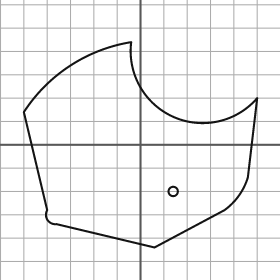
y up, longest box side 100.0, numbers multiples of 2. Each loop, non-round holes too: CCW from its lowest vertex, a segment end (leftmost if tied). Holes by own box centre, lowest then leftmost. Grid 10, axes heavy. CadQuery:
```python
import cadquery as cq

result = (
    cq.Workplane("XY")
    .moveTo(6.0, -44.0)
    .lineTo(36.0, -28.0)
    .threePointArc((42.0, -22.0), (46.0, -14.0))
    .lineTo(50.0, 20.0)
    .threePointArc((14.0, 12.0), (-4.0, 44.0))
    .threePointArc((-30.0, 34.0), (-50.0, 14.0))
    .lineTo(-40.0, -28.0)
    .threePointArc((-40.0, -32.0), (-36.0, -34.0))
    .close()
    .moveTo(14.0, -20.0)
    .circle(2.0)
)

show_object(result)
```